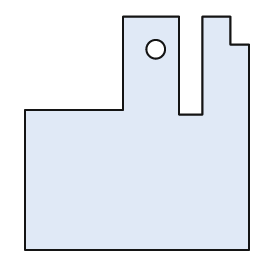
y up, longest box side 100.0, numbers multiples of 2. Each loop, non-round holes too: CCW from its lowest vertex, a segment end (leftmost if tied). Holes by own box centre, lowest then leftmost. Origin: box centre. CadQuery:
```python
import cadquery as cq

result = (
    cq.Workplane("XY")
    .moveTo(-48.0, -50.0)
    .lineTo(48.0, -50.0)
    .lineTo(48.0, 38.0)
    .lineTo(40.0, 38.0)
    .lineTo(40.0, 50.0)
    .lineTo(28.0, 50.0)
    .lineTo(28.0, 8.0)
    .lineTo(18.0, 8.0)
    .lineTo(18.0, 50.0)
    .lineTo(-6.0, 50.0)
    .lineTo(-6.0, 10.0)
    .lineTo(-48.0, 10.0)
    .close()
    .moveTo(8.0, 36.0)
    .circle(4.0)
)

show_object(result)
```